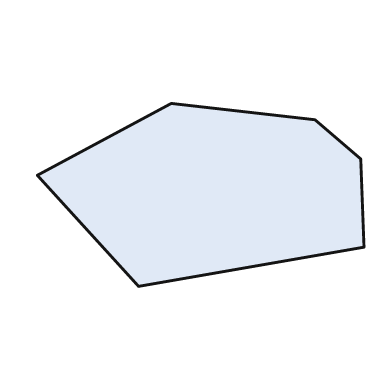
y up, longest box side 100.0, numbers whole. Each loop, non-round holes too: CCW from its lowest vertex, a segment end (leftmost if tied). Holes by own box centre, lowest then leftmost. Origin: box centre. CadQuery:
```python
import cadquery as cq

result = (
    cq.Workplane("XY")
    .moveTo(-19.0, -28.0)
    .lineTo(50.0, -16.0)
    .lineTo(49.0, 11.0)
    .lineTo(35.0, 23.0)
    .lineTo(-9.0, 28.0)
    .lineTo(-50.0, 6.0)
    .close()
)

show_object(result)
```